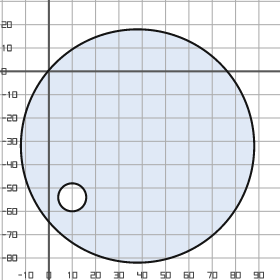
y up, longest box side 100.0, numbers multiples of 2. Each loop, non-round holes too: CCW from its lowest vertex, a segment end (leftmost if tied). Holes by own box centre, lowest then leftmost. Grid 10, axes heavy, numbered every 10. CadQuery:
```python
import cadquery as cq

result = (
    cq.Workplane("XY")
    .moveTo(38.0, -32.0)
    .circle(50.0)
    .moveTo(10.0, -54.0)
    .circle(6.0)
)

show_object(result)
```